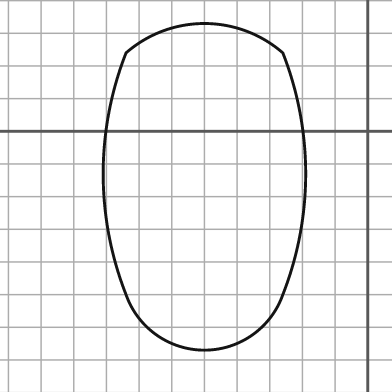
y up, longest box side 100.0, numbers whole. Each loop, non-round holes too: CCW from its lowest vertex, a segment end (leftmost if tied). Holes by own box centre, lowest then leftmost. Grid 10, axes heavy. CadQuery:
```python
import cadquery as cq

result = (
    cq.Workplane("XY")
    .moveTo(-74.0, -50.0)
    .threePointArc((-50.0, -67.0), (-26.0, -50.0))
    .threePointArc((-19.0, -13.0), (-26.0, 24.0))
    .threePointArc((-50.0, 33.0), (-74.0, 24.0))
    .threePointArc((-81.0, -13.0), (-74.0, -50.0))
    .close()
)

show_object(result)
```